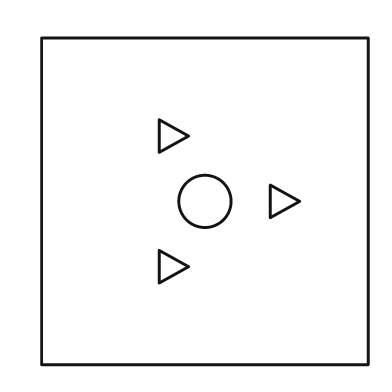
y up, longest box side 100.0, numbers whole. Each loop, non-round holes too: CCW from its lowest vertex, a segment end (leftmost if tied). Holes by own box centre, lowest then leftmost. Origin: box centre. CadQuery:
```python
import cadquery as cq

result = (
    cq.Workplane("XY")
    .moveTo(-50.0, -50.0)
    .lineTo(50.0, -50.0)
    .lineTo(50.0, 50.0)
    .lineTo(-50.0, 50.0)
    .close()
    .moveTo(-14.0, -25.0)
    .lineTo(-5.0, -20.0)
    .lineTo(-14.0, -15.0)
    .close()
    .moveTo(0.0, 0.0)
    .circle(8.0)
    .moveTo(20.0, -5.0)
    .lineTo(29.0, 0.0)
    .lineTo(20.0, 5.0)
    .close()
    .moveTo(-14.0, 15.0)
    .lineTo(-5.0, 20.0)
    .lineTo(-14.0, 25.0)
    .close()
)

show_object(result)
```